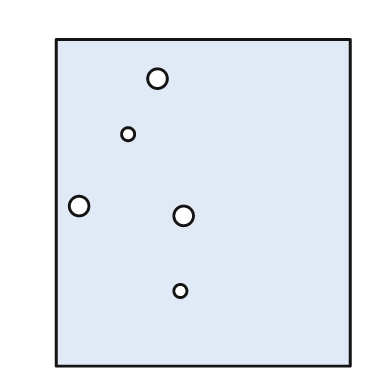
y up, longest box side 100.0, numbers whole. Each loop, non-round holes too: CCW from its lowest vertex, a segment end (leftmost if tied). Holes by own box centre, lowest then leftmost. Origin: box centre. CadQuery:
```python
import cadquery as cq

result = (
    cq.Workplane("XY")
    .moveTo(-45.0, -50.0)
    .lineTo(45.0, -50.0)
    .lineTo(45.0, 50.0)
    .lineTo(-45.0, 50.0)
    .close()
    .moveTo(-7.0, -27.0)
    .circle(2.0)
    .moveTo(-6.0, -4.0)
    .circle(3.0)
    .moveTo(-38.0, -1.0)
    .circle(3.0)
    .moveTo(-23.0, 21.0)
    .circle(2.0)
    .moveTo(-14.0, 38.0)
    .circle(3.0)
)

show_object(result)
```